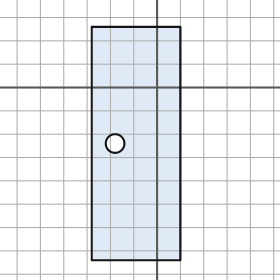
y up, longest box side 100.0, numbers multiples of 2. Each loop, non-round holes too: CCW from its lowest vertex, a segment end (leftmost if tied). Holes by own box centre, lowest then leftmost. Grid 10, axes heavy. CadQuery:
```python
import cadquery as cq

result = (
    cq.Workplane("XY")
    .moveTo(-28.0, -74.0)
    .lineTo(10.0, -74.0)
    .lineTo(10.0, 26.0)
    .lineTo(-28.0, 26.0)
    .close()
    .moveTo(-18.0, -24.0)
    .circle(4.0)
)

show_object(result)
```